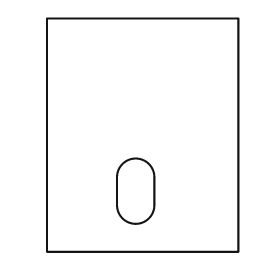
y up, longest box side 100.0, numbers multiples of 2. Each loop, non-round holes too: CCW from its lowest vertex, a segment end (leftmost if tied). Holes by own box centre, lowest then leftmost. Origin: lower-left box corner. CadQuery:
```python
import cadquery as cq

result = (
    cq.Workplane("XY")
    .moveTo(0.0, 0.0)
    .lineTo(82.0, 0.0)
    .lineTo(82.0, 100.0)
    .lineTo(0.0, 100.0)
    .close()
    .moveTo(30.0, 20.0)
    .threePointArc((38.0, 12.0), (46.0, 20.0))
    .lineTo(46.0, 32.0)
    .threePointArc((38.0, 40.0), (30.0, 32.0))
    .close()
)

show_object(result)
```